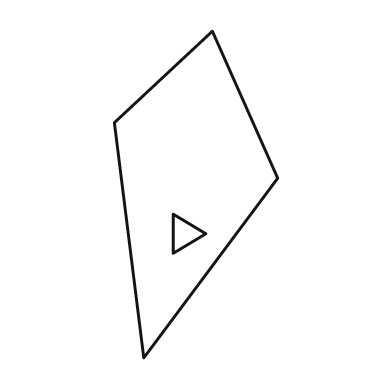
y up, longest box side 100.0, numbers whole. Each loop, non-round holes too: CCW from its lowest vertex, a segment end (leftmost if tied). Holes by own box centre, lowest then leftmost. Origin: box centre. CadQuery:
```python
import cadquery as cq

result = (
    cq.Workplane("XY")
    .moveTo(-16.0, -50.0)
    .lineTo(25.0, 5.0)
    .lineTo(5.0, 50.0)
    .lineTo(-25.0, 22.0)
    .close()
    .moveTo(-7.0, -18.0)
    .lineTo(3.0, -12.0)
    .lineTo(-7.0, -6.0)
    .close()
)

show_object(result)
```